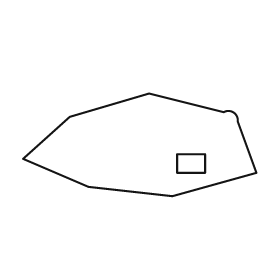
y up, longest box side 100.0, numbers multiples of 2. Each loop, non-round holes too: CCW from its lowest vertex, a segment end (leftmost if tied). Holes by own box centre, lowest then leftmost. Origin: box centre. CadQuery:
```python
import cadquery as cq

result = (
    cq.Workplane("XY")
    .moveTo(14.0, -22.0)
    .lineTo(50.0, -12.0)
    .lineTo(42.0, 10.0)
    .threePointArc((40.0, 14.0), (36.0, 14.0))
    .lineTo(4.0, 22.0)
    .lineTo(-30.0, 12.0)
    .lineTo(-50.0, -6.0)
    .lineTo(-22.0, -18.0)
    .close()
    .moveTo(16.0, -12.0)
    .lineTo(28.0, -12.0)
    .lineTo(28.0, -4.0)
    .lineTo(16.0, -4.0)
    .close()
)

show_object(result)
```